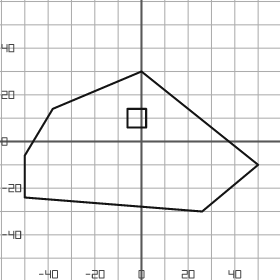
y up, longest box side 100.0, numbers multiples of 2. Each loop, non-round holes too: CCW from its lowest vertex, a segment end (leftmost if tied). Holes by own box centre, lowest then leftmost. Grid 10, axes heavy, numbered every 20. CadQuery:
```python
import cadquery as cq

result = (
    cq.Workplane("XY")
    .moveTo(26.0, -30.0)
    .lineTo(50.0, -10.0)
    .lineTo(0.0, 30.0)
    .lineTo(-38.0, 14.0)
    .lineTo(-50.0, -6.0)
    .lineTo(-50.0, -24.0)
    .close()
    .moveTo(-6.0, 6.0)
    .lineTo(2.0, 6.0)
    .lineTo(2.0, 14.0)
    .lineTo(-6.0, 14.0)
    .close()
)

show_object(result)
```